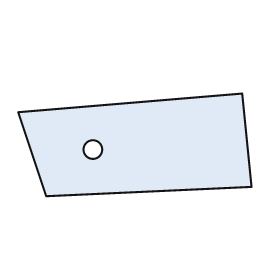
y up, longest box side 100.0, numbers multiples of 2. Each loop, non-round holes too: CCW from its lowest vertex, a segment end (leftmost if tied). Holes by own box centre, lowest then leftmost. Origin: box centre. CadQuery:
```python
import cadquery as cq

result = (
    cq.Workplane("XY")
    .moveTo(-38.0, -22.0)
    .lineTo(50.0, -18.0)
    .lineTo(46.0, 22.0)
    .lineTo(-50.0, 14.0)
    .close()
    .moveTo(-18.0, -2.0)
    .circle(4.0)
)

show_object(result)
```